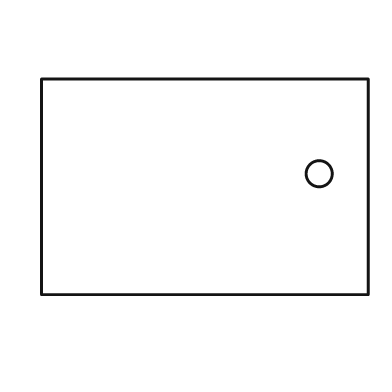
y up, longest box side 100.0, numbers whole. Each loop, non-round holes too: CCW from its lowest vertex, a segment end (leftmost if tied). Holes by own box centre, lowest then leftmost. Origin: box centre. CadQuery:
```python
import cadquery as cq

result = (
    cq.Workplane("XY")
    .moveTo(-50.0, -33.0)
    .lineTo(50.0, -33.0)
    .lineTo(50.0, 33.0)
    .lineTo(-50.0, 33.0)
    .close()
    .moveTo(35.0, 4.0)
    .circle(4.0)
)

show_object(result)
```